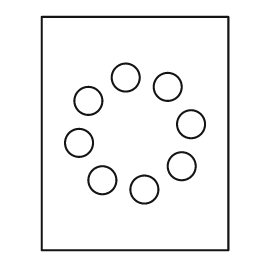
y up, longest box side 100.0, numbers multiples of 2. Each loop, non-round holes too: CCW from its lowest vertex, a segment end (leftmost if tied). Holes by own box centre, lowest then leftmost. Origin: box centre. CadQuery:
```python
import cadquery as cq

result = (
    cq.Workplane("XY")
    .moveTo(-40.0, -50.0)
    .lineTo(40.0, -50.0)
    .lineTo(40.0, 50.0)
    .lineTo(-40.0, 50.0)
    .close()
    .moveTo(4.0, -24.0)
    .circle(6.0)
    .moveTo(-14.0, -20.0)
    .circle(6.0)
    .moveTo(20.0, -14.0)
    .circle(6.0)
    .moveTo(-24.0, -4.0)
    .circle(6.0)
    .moveTo(24.0, 4.0)
    .circle(6.0)
    .moveTo(-20.0, 14.0)
    .circle(6.0)
    .moveTo(14.0, 20.0)
    .circle(6.0)
    .moveTo(-4.0, 24.0)
    .circle(6.0)
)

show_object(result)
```